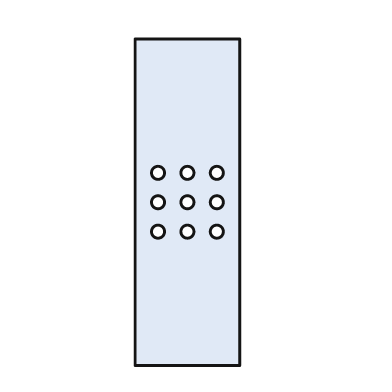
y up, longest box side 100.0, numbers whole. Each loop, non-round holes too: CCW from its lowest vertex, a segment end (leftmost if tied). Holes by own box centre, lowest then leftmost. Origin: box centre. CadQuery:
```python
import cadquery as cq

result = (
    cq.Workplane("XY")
    .moveTo(-16.0, -50.0)
    .lineTo(16.0, -50.0)
    .lineTo(16.0, 50.0)
    .lineTo(-16.0, 50.0)
    .close()
    .moveTo(-9.0, -9.0)
    .circle(2.0)
    .moveTo(0.0, -9.0)
    .circle(2.0)
    .moveTo(9.0, -9.0)
    .circle(2.0)
    .moveTo(-9.0, 0.0)
    .circle(2.0)
    .moveTo(0.0, 0.0)
    .circle(2.0)
    .moveTo(9.0, 0.0)
    .circle(2.0)
    .moveTo(-9.0, 9.0)
    .circle(2.0)
    .moveTo(0.0, 9.0)
    .circle(2.0)
    .moveTo(9.0, 9.0)
    .circle(2.0)
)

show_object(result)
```